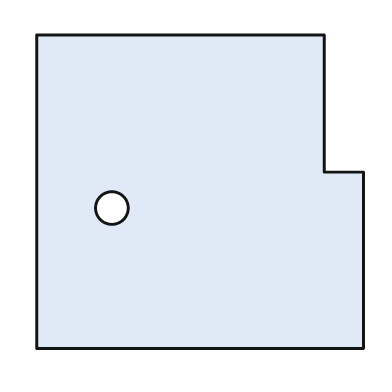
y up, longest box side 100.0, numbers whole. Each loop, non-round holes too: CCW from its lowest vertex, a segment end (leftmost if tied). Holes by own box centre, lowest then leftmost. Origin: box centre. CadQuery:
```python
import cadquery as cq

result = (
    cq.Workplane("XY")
    .moveTo(-50.0, -48.0)
    .lineTo(50.0, -48.0)
    .lineTo(50.0, 6.0)
    .lineTo(38.0, 6.0)
    .lineTo(38.0, 48.0)
    .lineTo(-50.0, 48.0)
    .close()
    .moveTo(-27.0, -5.0)
    .circle(5.0)
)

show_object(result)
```